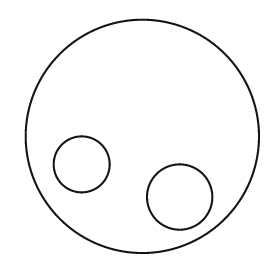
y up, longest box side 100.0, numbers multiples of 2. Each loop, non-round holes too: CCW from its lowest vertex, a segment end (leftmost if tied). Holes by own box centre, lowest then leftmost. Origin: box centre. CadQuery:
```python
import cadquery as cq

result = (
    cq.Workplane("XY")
    .moveTo(0.0, 0.0)
    .circle(50.0)
    .moveTo(16.0, -26.0)
    .circle(14.0)
    .moveTo(-26.0, -12.0)
    .circle(12.0)
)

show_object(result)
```